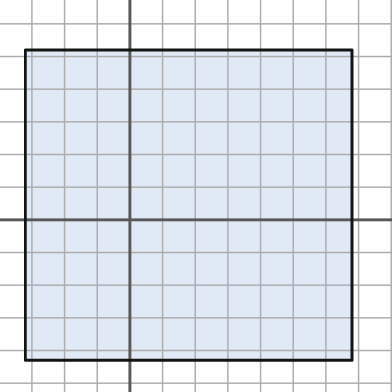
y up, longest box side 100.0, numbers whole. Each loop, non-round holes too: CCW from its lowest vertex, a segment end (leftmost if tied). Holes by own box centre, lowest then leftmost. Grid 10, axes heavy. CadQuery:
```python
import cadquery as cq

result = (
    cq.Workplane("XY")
    .moveTo(-32.0, -43.0)
    .lineTo(68.0, -43.0)
    .lineTo(68.0, 52.0)
    .lineTo(-32.0, 52.0)
    .close()
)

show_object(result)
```